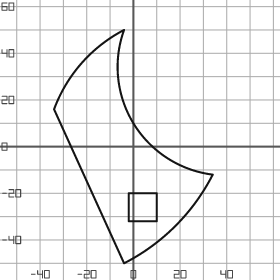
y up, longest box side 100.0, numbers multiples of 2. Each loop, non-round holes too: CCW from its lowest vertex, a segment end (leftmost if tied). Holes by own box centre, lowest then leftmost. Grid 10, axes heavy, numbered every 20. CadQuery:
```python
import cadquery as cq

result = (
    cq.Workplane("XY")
    .moveTo(-4.0, -50.0)
    .threePointArc((18.0, -34.0), (34.0, -12.0))
    .threePointArc((0.0, 10.0), (-4.0, 50.0))
    .threePointArc((-22.0, 36.0), (-34.0, 16.0))
    .close()
    .moveTo(-2.0, -32.0)
    .lineTo(10.0, -32.0)
    .lineTo(10.0, -20.0)
    .lineTo(-2.0, -20.0)
    .close()
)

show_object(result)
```